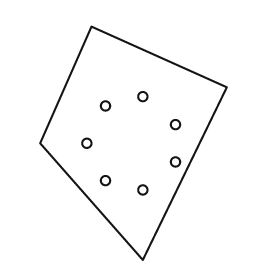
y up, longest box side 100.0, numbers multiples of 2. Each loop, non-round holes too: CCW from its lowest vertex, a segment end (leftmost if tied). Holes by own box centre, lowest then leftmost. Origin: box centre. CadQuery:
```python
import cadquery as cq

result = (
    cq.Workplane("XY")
    .moveTo(4.0, -50.0)
    .lineTo(40.0, 24.0)
    .lineTo(-18.0, 50.0)
    .lineTo(-40.0, 0.0)
    .close()
    .moveTo(4.0, -20.0)
    .circle(2.0)
    .moveTo(-12.0, -16.0)
    .circle(2.0)
    .moveTo(18.0, -8.0)
    .circle(2.0)
    .moveTo(-20.0, 0.0)
    .circle(2.0)
    .moveTo(18.0, 8.0)
    .circle(2.0)
    .moveTo(-12.0, 16.0)
    .circle(2.0)
    .moveTo(4.0, 20.0)
    .circle(2.0)
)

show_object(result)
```